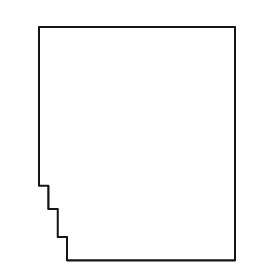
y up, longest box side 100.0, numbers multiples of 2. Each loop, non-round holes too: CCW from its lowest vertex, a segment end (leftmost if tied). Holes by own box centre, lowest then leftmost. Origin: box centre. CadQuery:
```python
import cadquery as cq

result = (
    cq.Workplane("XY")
    .moveTo(-30.0, -50.0)
    .lineTo(42.0, -50.0)
    .lineTo(42.0, 50.0)
    .lineTo(-42.0, 50.0)
    .lineTo(-42.0, -18.0)
    .lineTo(-38.0, -18.0)
    .lineTo(-38.0, -28.0)
    .lineTo(-34.0, -28.0)
    .lineTo(-34.0, -40.0)
    .lineTo(-30.0, -40.0)
    .close()
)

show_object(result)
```